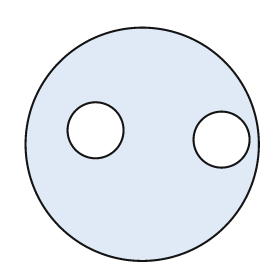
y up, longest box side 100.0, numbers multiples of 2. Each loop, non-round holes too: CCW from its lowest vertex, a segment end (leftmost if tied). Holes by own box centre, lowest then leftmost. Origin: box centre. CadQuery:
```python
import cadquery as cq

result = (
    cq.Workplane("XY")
    .moveTo(0.0, 0.0)
    .circle(50.0)
    .moveTo(34.0, 2.0)
    .circle(12.0)
    .moveTo(-20.0, 6.0)
    .circle(12.0)
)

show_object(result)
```